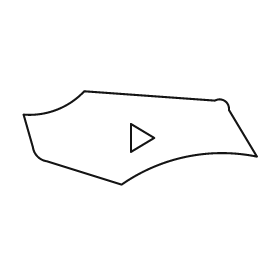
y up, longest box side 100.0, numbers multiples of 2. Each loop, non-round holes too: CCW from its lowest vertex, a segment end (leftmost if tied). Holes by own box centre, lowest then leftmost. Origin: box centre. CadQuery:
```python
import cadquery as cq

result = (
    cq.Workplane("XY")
    .moveTo(-8.0, -20.0)
    .threePointArc((20.0, -8.0), (50.0, -8.0))
    .lineTo(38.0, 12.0)
    .threePointArc((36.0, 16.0), (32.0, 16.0))
    .lineTo(-24.0, 20.0)
    .threePointArc((-36.0, 12.0), (-50.0, 10.0))
    .lineTo(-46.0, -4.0)
    .threePointArc((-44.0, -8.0), (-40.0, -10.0))
    .close()
    .moveTo(-4.0, -6.0)
    .lineTo(6.0, 0.0)
    .lineTo(-4.0, 6.0)
    .close()
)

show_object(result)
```